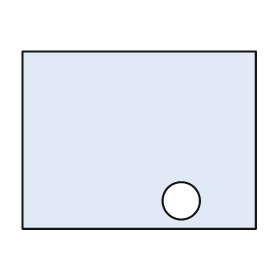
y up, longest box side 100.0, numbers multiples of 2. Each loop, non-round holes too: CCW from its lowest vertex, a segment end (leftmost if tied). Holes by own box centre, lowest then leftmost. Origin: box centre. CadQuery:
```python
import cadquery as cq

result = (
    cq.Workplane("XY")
    .moveTo(-50.0, -38.0)
    .lineTo(50.0, -38.0)
    .lineTo(50.0, 38.0)
    .lineTo(-50.0, 38.0)
    .close()
    .moveTo(18.0, -26.0)
    .circle(8.0)
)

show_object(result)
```